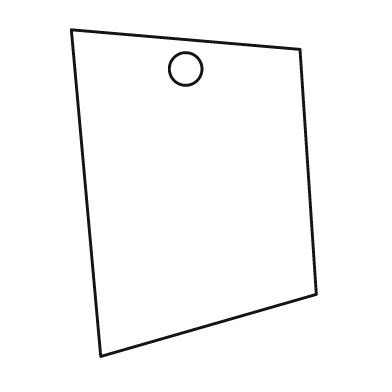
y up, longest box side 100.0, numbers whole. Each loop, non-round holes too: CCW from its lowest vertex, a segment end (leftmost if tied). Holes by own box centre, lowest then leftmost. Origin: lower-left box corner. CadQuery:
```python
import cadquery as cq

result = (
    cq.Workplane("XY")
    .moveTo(9.0, 0.0)
    .lineTo(75.0, 19.0)
    .lineTo(70.0, 94.0)
    .lineTo(0.0, 100.0)
    .close()
    .moveTo(35.0, 88.0)
    .circle(5.0)
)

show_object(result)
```